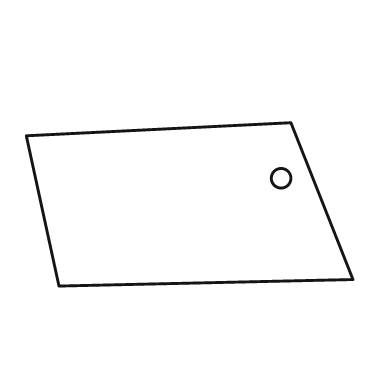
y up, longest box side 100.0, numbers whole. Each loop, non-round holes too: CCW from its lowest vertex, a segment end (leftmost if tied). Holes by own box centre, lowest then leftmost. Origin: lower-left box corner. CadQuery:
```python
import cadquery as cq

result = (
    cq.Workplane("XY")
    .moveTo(10.0, 0.0)
    .lineTo(100.0, 2.0)
    .lineTo(81.0, 50.0)
    .lineTo(0.0, 46.0)
    .close()
    .moveTo(78.0, 33.0)
    .circle(3.0)
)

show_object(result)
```